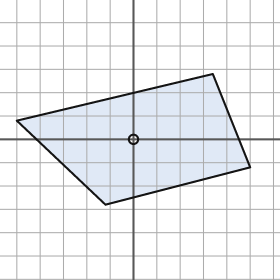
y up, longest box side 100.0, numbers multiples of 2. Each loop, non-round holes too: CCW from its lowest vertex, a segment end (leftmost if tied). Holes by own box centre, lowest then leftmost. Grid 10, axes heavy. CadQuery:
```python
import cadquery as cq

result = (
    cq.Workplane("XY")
    .moveTo(-12.0, -28.0)
    .lineTo(50.0, -12.0)
    .lineTo(34.0, 28.0)
    .lineTo(-50.0, 8.0)
    .close()
    .moveTo(0.0, 0.0)
    .circle(2.0)
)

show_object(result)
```